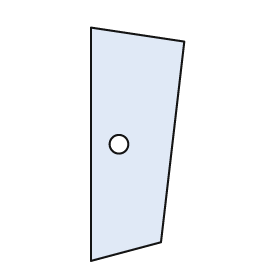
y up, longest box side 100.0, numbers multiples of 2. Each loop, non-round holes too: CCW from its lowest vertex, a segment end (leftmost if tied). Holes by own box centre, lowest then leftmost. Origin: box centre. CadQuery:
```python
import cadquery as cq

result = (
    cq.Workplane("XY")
    .moveTo(-20.0, -50.0)
    .lineTo(10.0, -42.0)
    .lineTo(20.0, 44.0)
    .lineTo(-20.0, 50.0)
    .close()
    .moveTo(-8.0, 0.0)
    .circle(4.0)
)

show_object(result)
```